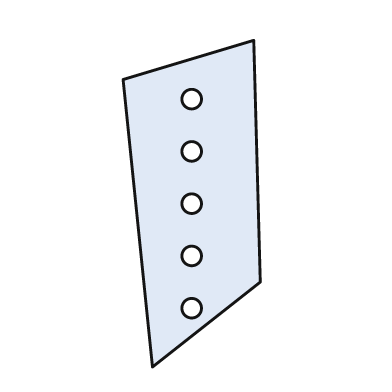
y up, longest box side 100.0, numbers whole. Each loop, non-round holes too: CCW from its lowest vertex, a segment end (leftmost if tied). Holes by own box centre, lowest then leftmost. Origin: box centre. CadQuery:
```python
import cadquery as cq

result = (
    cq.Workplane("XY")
    .moveTo(-12.0, -50.0)
    .lineTo(21.0, -24.0)
    .lineTo(19.0, 50.0)
    .lineTo(-21.0, 38.0)
    .close()
    .moveTo(0.0, -32.0)
    .circle(3.0)
    .moveTo(0.0, -16.0)
    .circle(3.0)
    .moveTo(0.0, 0.0)
    .circle(3.0)
    .moveTo(0.0, 16.0)
    .circle(3.0)
    .moveTo(0.0, 32.0)
    .circle(3.0)
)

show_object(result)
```